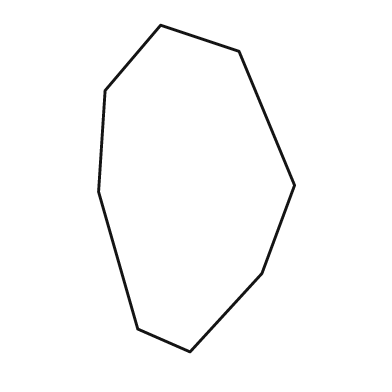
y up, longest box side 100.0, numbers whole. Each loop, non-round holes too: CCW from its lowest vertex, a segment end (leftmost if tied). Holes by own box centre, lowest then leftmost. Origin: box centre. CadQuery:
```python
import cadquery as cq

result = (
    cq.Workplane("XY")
    .moveTo(-2.0, -50.0)
    .lineTo(20.0, -26.0)
    .lineTo(30.0, 1.0)
    .lineTo(13.0, 42.0)
    .lineTo(-11.0, 50.0)
    .lineTo(-28.0, 30.0)
    .lineTo(-30.0, -1.0)
    .lineTo(-18.0, -43.0)
    .close()
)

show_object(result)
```